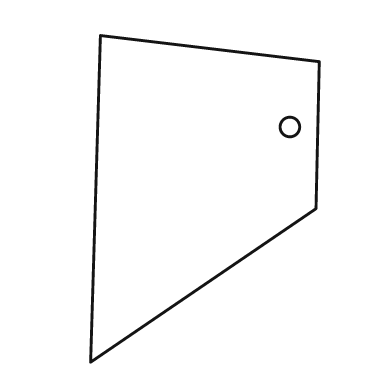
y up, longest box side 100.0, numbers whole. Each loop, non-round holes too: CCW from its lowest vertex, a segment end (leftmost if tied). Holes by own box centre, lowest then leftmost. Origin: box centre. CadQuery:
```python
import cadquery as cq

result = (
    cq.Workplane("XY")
    .moveTo(-35.0, -50.0)
    .lineTo(34.0, -3.0)
    .lineTo(35.0, 42.0)
    .lineTo(-32.0, 50.0)
    .close()
    .moveTo(26.0, 22.0)
    .circle(3.0)
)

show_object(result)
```